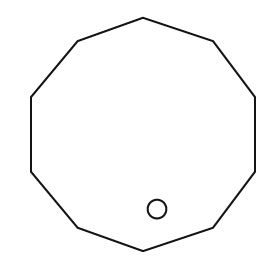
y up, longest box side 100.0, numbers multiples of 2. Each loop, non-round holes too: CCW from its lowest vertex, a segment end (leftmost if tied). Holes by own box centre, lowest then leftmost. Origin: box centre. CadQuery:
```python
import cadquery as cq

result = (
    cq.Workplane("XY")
    .moveTo(0.0, -50.0)
    .lineTo(30.0, -40.0)
    .lineTo(48.0, -16.0)
    .lineTo(48.0, 16.0)
    .lineTo(30.0, 40.0)
    .lineTo(0.0, 50.0)
    .lineTo(-28.0, 40.0)
    .lineTo(-48.0, 16.0)
    .lineTo(-48.0, -16.0)
    .lineTo(-28.0, -40.0)
    .close()
    .moveTo(6.0, -32.0)
    .circle(4.0)
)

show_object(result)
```